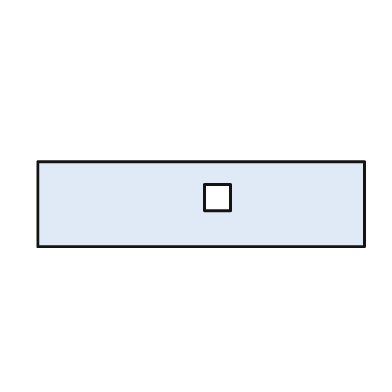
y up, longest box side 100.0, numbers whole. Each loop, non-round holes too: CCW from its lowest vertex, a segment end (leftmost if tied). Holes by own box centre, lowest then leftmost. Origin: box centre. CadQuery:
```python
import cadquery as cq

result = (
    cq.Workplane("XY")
    .moveTo(-50.0, -13.0)
    .lineTo(50.0, -13.0)
    .lineTo(50.0, 13.0)
    .lineTo(-50.0, 13.0)
    .close()
    .moveTo(1.0, -2.0)
    .lineTo(9.0, -2.0)
    .lineTo(9.0, 6.0)
    .lineTo(1.0, 6.0)
    .close()
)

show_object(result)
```